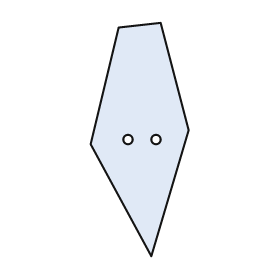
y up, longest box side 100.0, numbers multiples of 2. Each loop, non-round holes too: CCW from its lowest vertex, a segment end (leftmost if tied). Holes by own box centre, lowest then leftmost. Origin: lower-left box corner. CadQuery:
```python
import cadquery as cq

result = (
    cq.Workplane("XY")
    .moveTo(26.0, 0.0)
    .lineTo(42.0, 54.0)
    .lineTo(30.0, 100.0)
    .lineTo(12.0, 98.0)
    .lineTo(0.0, 48.0)
    .close()
    .moveTo(16.0, 50.0)
    .circle(2.0)
    .moveTo(28.0, 50.0)
    .circle(2.0)
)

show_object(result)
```